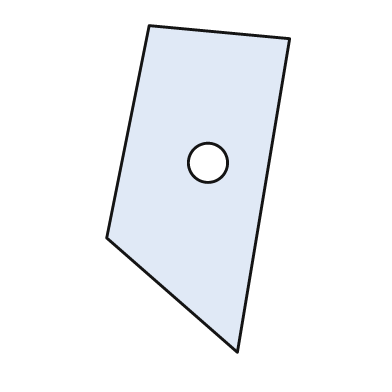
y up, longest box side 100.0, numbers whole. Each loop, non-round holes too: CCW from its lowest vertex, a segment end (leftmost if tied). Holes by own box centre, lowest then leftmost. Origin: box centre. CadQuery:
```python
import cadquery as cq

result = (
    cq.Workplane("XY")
    .moveTo(12.0, -50.0)
    .lineTo(28.0, 46.0)
    .lineTo(-15.0, 50.0)
    .lineTo(-28.0, -15.0)
    .close()
    .moveTo(3.0, 8.0)
    .circle(6.0)
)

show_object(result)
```